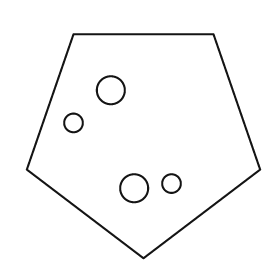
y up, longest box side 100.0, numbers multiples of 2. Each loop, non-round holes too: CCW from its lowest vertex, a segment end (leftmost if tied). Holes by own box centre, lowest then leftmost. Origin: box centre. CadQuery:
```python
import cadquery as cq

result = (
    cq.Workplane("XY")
    .moveTo(0.0, -48.0)
    .lineTo(50.0, -10.0)
    .lineTo(30.0, 48.0)
    .lineTo(-30.0, 48.0)
    .lineTo(-50.0, -10.0)
    .close()
    .moveTo(-4.0, -18.0)
    .circle(6.0)
    .moveTo(12.0, -16.0)
    .circle(4.0)
    .moveTo(-30.0, 10.0)
    .circle(4.0)
    .moveTo(-14.0, 24.0)
    .circle(6.0)
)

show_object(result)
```